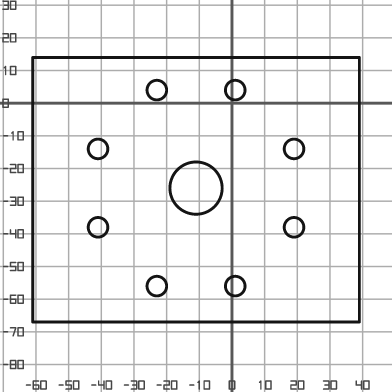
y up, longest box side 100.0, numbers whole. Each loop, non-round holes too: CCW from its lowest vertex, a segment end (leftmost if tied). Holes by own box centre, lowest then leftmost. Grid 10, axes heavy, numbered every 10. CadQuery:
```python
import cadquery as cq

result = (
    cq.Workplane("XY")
    .moveTo(-61.0, -67.0)
    .lineTo(39.0, -67.0)
    .lineTo(39.0, 14.0)
    .lineTo(-61.0, 14.0)
    .close()
    .moveTo(-23.0, -56.0)
    .circle(3.0)
    .moveTo(1.0, -56.0)
    .circle(3.0)
    .moveTo(-41.0, -38.0)
    .circle(3.0)
    .moveTo(19.0, -38.0)
    .circle(3.0)
    .moveTo(-11.0, -26.0)
    .circle(8.0)
    .moveTo(-41.0, -14.0)
    .circle(3.0)
    .moveTo(19.0, -14.0)
    .circle(3.0)
    .moveTo(-23.0, 4.0)
    .circle(3.0)
    .moveTo(1.0, 4.0)
    .circle(3.0)
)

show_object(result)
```